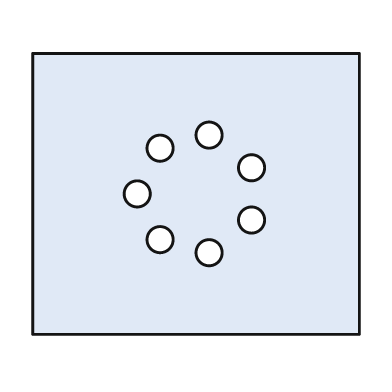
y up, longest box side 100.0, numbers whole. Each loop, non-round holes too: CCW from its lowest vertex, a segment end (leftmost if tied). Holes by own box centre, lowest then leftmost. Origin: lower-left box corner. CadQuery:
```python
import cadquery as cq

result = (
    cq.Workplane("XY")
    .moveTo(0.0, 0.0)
    .lineTo(100.0, 0.0)
    .lineTo(100.0, 86.0)
    .lineTo(0.0, 86.0)
    .close()
    .moveTo(54.0, 25.0)
    .circle(4.0)
    .moveTo(39.0, 29.0)
    .circle(4.0)
    .moveTo(67.0, 35.0)
    .circle(4.0)
    .moveTo(32.0, 43.0)
    .circle(4.0)
    .moveTo(67.0, 51.0)
    .circle(4.0)
    .moveTo(39.0, 57.0)
    .circle(4.0)
    .moveTo(54.0, 61.0)
    .circle(4.0)
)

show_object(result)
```